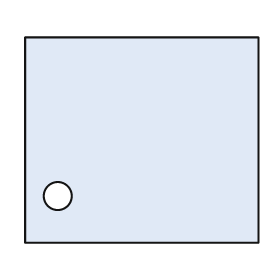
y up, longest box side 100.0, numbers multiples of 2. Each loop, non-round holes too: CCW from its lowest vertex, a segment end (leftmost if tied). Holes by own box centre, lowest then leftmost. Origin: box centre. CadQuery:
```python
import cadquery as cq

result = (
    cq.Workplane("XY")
    .moveTo(-50.0, -44.0)
    .lineTo(50.0, -44.0)
    .lineTo(50.0, 44.0)
    .lineTo(-50.0, 44.0)
    .close()
    .moveTo(-36.0, -24.0)
    .circle(6.0)
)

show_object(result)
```